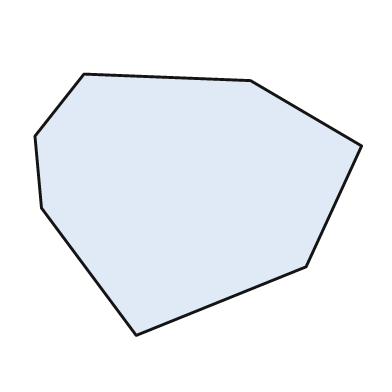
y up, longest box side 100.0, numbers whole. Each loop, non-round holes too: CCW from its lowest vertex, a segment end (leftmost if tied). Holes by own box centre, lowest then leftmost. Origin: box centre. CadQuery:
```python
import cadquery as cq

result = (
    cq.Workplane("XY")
    .moveTo(-19.0, -40.0)
    .lineTo(33.0, -19.0)
    .lineTo(50.0, 18.0)
    .lineTo(16.0, 38.0)
    .lineTo(-35.0, 40.0)
    .lineTo(-50.0, 21.0)
    .lineTo(-48.0, -1.0)
    .close()
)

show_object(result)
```